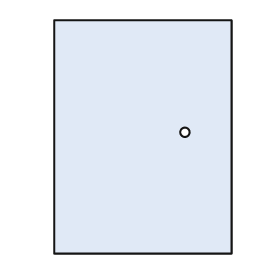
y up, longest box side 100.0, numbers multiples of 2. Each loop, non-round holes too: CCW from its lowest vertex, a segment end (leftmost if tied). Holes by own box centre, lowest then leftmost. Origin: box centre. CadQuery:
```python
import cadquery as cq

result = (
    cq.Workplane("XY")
    .moveTo(-38.0, -50.0)
    .lineTo(38.0, -50.0)
    .lineTo(38.0, 50.0)
    .lineTo(-38.0, 50.0)
    .close()
    .moveTo(18.0, 2.0)
    .circle(2.0)
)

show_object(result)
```